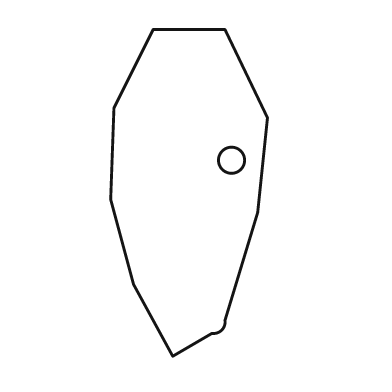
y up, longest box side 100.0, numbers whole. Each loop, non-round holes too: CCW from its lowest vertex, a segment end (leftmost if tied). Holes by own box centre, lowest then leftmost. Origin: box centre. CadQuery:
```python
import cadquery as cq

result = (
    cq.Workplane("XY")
    .moveTo(-5.0, -50.0)
    .lineTo(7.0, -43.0)
    .threePointArc((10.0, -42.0), (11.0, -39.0))
    .lineTo(21.0, -6.0)
    .lineTo(24.0, 23.0)
    .lineTo(11.0, 50.0)
    .lineTo(-11.0, 50.0)
    .lineTo(-23.0, 26.0)
    .lineTo(-24.0, -2.0)
    .lineTo(-17.0, -28.0)
    .close()
    .moveTo(13.0, 10.0)
    .circle(4.0)
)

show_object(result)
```